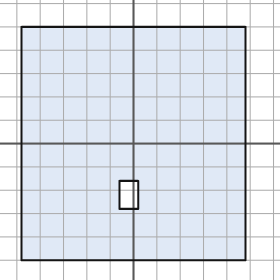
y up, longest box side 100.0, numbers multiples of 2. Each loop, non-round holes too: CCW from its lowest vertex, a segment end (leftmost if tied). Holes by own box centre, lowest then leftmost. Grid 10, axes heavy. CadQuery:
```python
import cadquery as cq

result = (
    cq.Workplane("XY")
    .moveTo(-48.0, -50.0)
    .lineTo(48.0, -50.0)
    .lineTo(48.0, 50.0)
    .lineTo(-48.0, 50.0)
    .close()
    .moveTo(-6.0, -28.0)
    .lineTo(2.0, -28.0)
    .lineTo(2.0, -16.0)
    .lineTo(-6.0, -16.0)
    .close()
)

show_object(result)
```